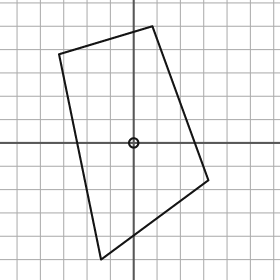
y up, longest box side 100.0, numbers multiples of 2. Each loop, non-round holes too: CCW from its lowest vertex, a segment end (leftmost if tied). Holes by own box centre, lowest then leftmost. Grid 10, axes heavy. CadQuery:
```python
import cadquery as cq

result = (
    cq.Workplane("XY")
    .moveTo(-14.0, -50.0)
    .lineTo(32.0, -16.0)
    .lineTo(8.0, 50.0)
    .lineTo(-32.0, 38.0)
    .close()
    .moveTo(0.0, 0.0)
    .circle(2.0)
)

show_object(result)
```